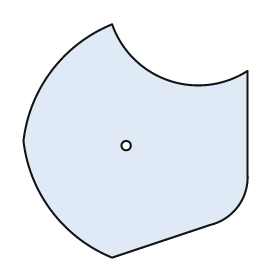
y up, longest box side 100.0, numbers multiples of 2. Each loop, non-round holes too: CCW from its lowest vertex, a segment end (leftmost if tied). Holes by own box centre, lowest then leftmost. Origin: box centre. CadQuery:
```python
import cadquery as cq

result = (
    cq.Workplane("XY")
    .moveTo(-10.0, -50.0)
    .lineTo(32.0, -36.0)
    .threePointArc((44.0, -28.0), (48.0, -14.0))
    .lineTo(48.0, 30.0)
    .threePointArc((14.0, 26.0), (-10.0, 50.0))
    .threePointArc((-36.0, 30.0), (-48.0, 0.0))
    .threePointArc((-36.0, -30.0), (-10.0, -50.0))
    .close()
    .moveTo(-4.0, -2.0)
    .circle(2.0)
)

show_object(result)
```